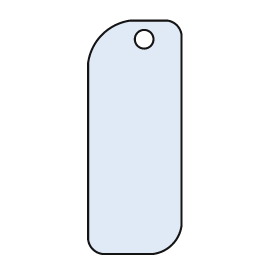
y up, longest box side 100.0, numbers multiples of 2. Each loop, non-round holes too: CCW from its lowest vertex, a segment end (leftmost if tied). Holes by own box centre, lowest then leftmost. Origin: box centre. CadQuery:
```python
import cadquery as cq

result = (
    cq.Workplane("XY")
    .moveTo(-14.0, -50.0)
    .lineTo(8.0, -50.0)
    .threePointArc((16.0, -46.0), (20.0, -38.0))
    .lineTo(20.0, 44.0)
    .threePointArc((18.0, 48.0), (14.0, 50.0))
    .lineTo(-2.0, 50.0)
    .threePointArc((-14.0, 44.0), (-20.0, 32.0))
    .lineTo(-20.0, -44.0)
    .threePointArc((-18.0, -48.0), (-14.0, -50.0))
    .close()
    .moveTo(4.0, 42.0)
    .circle(4.0)
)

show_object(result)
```